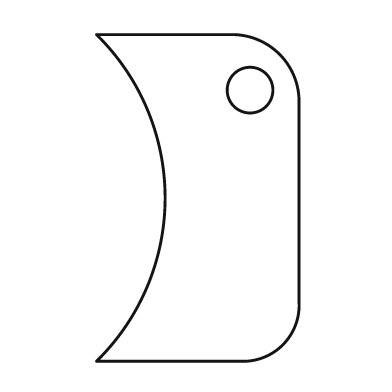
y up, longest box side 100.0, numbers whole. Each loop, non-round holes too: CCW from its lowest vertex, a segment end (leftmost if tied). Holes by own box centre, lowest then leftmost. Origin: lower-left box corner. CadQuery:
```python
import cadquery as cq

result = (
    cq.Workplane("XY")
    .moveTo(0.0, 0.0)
    .lineTo(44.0, 0.0)
    .threePointArc((57.0, 5.0), (62.0, 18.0))
    .lineTo(62.0, 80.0)
    .threePointArc((56.0, 94.0), (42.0, 100.0))
    .lineTo(0.0, 100.0)
    .threePointArc((21.0, 50.0), (0.0, 0.0))
    .close()
    .moveTo(47.0, 83.0)
    .circle(7.0)
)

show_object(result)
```